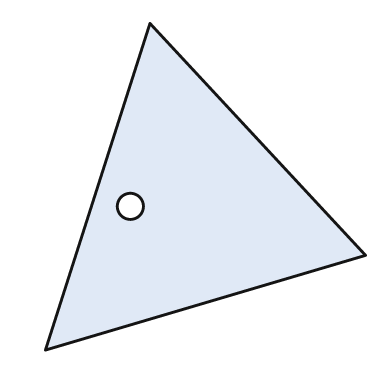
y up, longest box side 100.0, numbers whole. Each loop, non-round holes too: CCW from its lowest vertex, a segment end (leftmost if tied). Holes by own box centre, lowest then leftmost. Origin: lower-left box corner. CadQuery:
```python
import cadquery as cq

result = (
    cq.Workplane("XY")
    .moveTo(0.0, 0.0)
    .lineTo(98.0, 29.0)
    .lineTo(32.0, 100.0)
    .close()
    .moveTo(26.0, 44.0)
    .circle(4.0)
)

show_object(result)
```